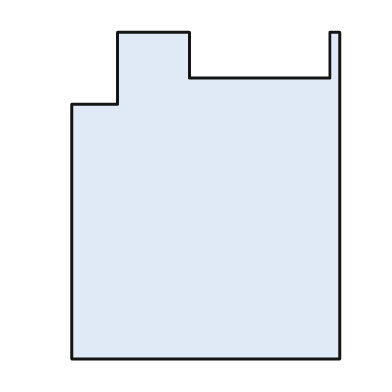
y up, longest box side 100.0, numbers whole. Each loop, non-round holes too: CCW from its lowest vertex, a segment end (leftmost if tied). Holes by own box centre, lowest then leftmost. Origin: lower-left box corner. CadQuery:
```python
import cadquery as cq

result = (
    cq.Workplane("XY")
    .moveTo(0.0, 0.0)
    .lineTo(82.0, 0.0)
    .lineTo(82.0, 100.0)
    .lineTo(79.0, 100.0)
    .lineTo(79.0, 86.0)
    .lineTo(36.0, 86.0)
    .lineTo(36.0, 100.0)
    .lineTo(14.0, 100.0)
    .lineTo(14.0, 78.0)
    .lineTo(0.0, 78.0)
    .close()
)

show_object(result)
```